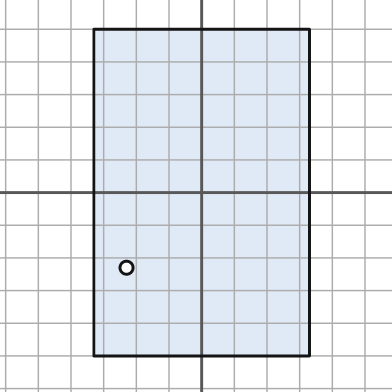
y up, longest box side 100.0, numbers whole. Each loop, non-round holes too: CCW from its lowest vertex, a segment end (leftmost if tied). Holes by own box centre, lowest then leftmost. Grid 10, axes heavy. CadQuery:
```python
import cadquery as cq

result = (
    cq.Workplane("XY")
    .moveTo(-33.0, -50.0)
    .lineTo(33.0, -50.0)
    .lineTo(33.0, 50.0)
    .lineTo(-33.0, 50.0)
    .close()
    .moveTo(-23.0, -23.0)
    .circle(2.0)
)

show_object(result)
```